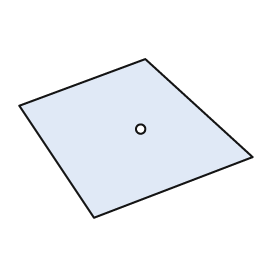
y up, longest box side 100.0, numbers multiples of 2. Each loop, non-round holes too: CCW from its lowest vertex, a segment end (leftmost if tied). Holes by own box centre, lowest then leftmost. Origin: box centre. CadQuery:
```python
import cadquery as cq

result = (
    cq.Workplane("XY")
    .moveTo(-18.0, -34.0)
    .lineTo(50.0, -8.0)
    .lineTo(4.0, 34.0)
    .lineTo(-50.0, 14.0)
    .close()
    .moveTo(2.0, 4.0)
    .circle(2.0)
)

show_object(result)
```